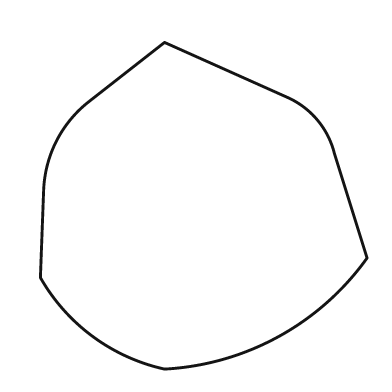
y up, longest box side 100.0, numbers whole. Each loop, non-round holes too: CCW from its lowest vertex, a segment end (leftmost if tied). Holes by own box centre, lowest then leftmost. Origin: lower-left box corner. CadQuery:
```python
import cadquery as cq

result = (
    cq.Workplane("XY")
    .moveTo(38.0, 0.0)
    .threePointArc((73.0, 10.0), (100.0, 34.0))
    .lineTo(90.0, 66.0)
    .threePointArc((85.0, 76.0), (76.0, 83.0))
    .lineTo(38.0, 100.0)
    .lineTo(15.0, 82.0)
    .threePointArc((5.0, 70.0), (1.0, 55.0))
    .lineTo(0.0, 28.0)
    .threePointArc((16.0, 10.0), (38.0, 0.0))
    .close()
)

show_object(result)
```